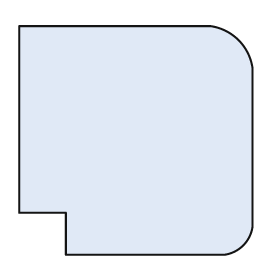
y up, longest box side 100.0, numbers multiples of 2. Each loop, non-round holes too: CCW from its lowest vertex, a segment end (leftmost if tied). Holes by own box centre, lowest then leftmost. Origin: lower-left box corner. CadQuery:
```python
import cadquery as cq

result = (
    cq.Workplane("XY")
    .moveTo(20.0, 0.0)
    .lineTo(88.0, 0.0)
    .threePointArc((96.0, 4.0), (100.0, 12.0))
    .lineTo(100.0, 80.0)
    .threePointArc((94.0, 92.0), (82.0, 98.0))
    .lineTo(0.0, 98.0)
    .lineTo(0.0, 18.0)
    .lineTo(20.0, 18.0)
    .close()
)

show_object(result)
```